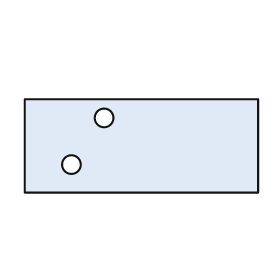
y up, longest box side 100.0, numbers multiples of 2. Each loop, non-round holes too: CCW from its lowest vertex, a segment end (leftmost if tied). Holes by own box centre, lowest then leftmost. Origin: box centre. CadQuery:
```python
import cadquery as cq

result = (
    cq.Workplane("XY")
    .moveTo(-50.0, -20.0)
    .lineTo(50.0, -20.0)
    .lineTo(50.0, 20.0)
    .lineTo(-50.0, 20.0)
    .close()
    .moveTo(-30.0, -8.0)
    .circle(4.0)
    .moveTo(-16.0, 12.0)
    .circle(4.0)
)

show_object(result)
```